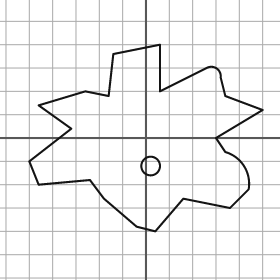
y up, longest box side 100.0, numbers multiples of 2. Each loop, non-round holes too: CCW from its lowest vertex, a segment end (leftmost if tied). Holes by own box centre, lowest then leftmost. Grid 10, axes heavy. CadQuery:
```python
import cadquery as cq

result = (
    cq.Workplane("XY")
    .moveTo(4.0, -40.0)
    .lineTo(16.0, -26.0)
    .lineTo(36.0, -30.0)
    .lineTo(44.0, -22.0)
    .threePointArc((42.0, -12.0), (34.0, -6.0))
    .lineTo(30.0, 0.0)
    .lineTo(50.0, 12.0)
    .lineTo(34.0, 18.0)
    .lineTo(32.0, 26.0)
    .threePointArc((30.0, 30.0), (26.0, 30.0))
    .lineTo(6.0, 20.0)
    .lineTo(6.0, 40.0)
    .lineTo(-14.0, 36.0)
    .lineTo(-16.0, 18.0)
    .lineTo(-26.0, 20.0)
    .lineTo(-46.0, 14.0)
    .lineTo(-32.0, 4.0)
    .lineTo(-50.0, -10.0)
    .lineTo(-46.0, -20.0)
    .lineTo(-24.0, -18.0)
    .lineTo(-18.0, -26.0)
    .lineTo(-4.0, -38.0)
    .close()
    .moveTo(2.0, -12.0)
    .circle(4.0)
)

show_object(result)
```